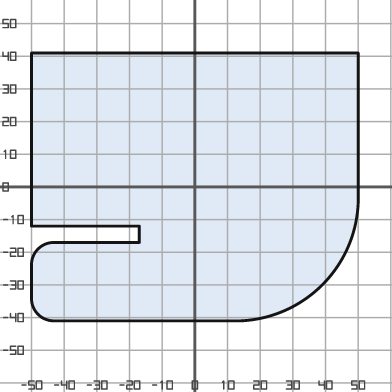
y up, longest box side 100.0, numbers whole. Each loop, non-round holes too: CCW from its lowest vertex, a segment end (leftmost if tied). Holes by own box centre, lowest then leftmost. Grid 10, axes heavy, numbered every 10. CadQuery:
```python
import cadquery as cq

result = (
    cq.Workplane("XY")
    .moveTo(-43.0, -41.0)
    .lineTo(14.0, -41.0)
    .threePointArc((39.0, -30.0), (50.0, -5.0))
    .lineTo(50.0, 41.0)
    .lineTo(-50.0, 41.0)
    .lineTo(-50.0, -12.0)
    .lineTo(-17.0, -12.0)
    .lineTo(-17.0, -17.0)
    .lineTo(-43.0, -17.0)
    .threePointArc((-48.0, -19.0), (-50.0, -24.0))
    .lineTo(-50.0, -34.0)
    .threePointArc((-48.0, -39.0), (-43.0, -41.0))
    .close()
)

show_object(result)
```